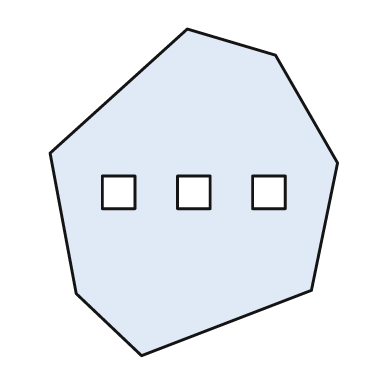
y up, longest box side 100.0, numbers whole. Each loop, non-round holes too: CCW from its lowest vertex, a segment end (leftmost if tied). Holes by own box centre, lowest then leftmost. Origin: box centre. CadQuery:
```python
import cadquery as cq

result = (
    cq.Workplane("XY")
    .moveTo(-16.0, -50.0)
    .lineTo(36.0, -30.0)
    .lineTo(44.0, 9.0)
    .lineTo(25.0, 42.0)
    .lineTo(-2.0, 50.0)
    .lineTo(-44.0, 12.0)
    .lineTo(-36.0, -31.0)
    .close()
    .moveTo(-28.0, -5.0)
    .lineTo(-18.0, -5.0)
    .lineTo(-18.0, 5.0)
    .lineTo(-28.0, 5.0)
    .close()
    .moveTo(-5.0, -5.0)
    .lineTo(5.0, -5.0)
    .lineTo(5.0, 5.0)
    .lineTo(-5.0, 5.0)
    .close()
    .moveTo(18.0, -5.0)
    .lineTo(28.0, -5.0)
    .lineTo(28.0, 5.0)
    .lineTo(18.0, 5.0)
    .close()
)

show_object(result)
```